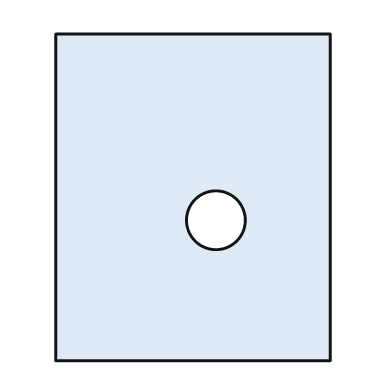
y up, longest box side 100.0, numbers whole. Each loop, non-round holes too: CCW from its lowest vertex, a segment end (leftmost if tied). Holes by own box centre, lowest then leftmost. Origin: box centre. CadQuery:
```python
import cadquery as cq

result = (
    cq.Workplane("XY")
    .moveTo(-42.0, -50.0)
    .lineTo(42.0, -50.0)
    .lineTo(42.0, 50.0)
    .lineTo(-42.0, 50.0)
    .close()
    .moveTo(7.0, -7.0)
    .circle(9.0)
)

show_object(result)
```